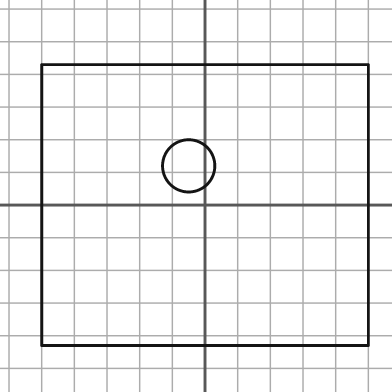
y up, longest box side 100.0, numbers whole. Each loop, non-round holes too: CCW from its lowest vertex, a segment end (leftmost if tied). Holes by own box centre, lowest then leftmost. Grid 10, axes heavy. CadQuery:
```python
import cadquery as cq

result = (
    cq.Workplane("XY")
    .moveTo(-50.0, -43.0)
    .lineTo(50.0, -43.0)
    .lineTo(50.0, 43.0)
    .lineTo(-50.0, 43.0)
    .close()
    .moveTo(-5.0, 12.0)
    .circle(8.0)
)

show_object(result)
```